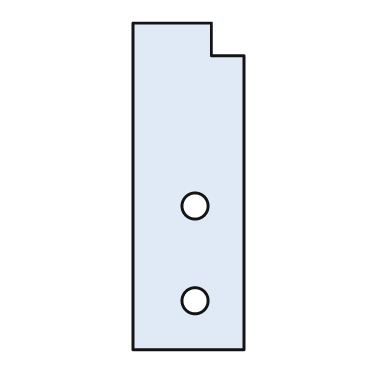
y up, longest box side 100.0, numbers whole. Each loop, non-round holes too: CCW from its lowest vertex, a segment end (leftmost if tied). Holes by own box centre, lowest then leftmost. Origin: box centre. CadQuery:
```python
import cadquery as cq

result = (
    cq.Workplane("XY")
    .moveTo(-17.0, -50.0)
    .lineTo(17.0, -50.0)
    .lineTo(17.0, 40.0)
    .lineTo(7.0, 40.0)
    .lineTo(7.0, 50.0)
    .lineTo(-17.0, 50.0)
    .close()
    .moveTo(2.0, -35.0)
    .circle(4.0)
    .moveTo(2.0, -6.0)
    .circle(4.0)
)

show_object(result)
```